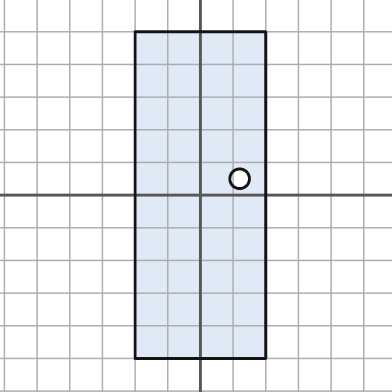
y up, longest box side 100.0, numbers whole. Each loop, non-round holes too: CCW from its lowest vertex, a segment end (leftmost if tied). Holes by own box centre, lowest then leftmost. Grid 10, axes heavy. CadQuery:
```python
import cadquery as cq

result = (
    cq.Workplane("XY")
    .moveTo(-20.0, -50.0)
    .lineTo(20.0, -50.0)
    .lineTo(20.0, 50.0)
    .lineTo(-20.0, 50.0)
    .close()
    .moveTo(12.0, 5.0)
    .circle(3.0)
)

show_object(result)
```